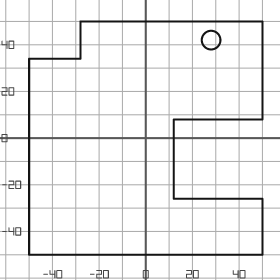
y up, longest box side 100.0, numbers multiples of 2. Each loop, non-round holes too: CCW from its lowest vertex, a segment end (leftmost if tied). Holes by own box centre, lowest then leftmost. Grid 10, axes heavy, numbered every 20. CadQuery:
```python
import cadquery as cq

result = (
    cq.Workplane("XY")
    .moveTo(-50.0, -50.0)
    .lineTo(50.0, -50.0)
    .lineTo(50.0, -26.0)
    .lineTo(12.0, -26.0)
    .lineTo(12.0, 8.0)
    .lineTo(50.0, 8.0)
    .lineTo(50.0, 50.0)
    .lineTo(-28.0, 50.0)
    .lineTo(-28.0, 34.0)
    .lineTo(-50.0, 34.0)
    .close()
    .moveTo(28.0, 42.0)
    .circle(4.0)
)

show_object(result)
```